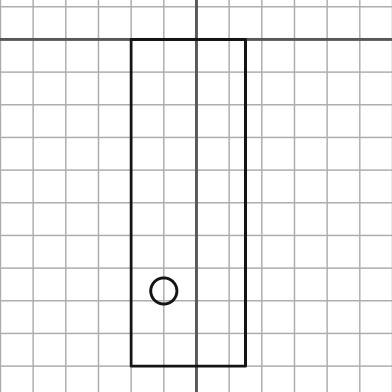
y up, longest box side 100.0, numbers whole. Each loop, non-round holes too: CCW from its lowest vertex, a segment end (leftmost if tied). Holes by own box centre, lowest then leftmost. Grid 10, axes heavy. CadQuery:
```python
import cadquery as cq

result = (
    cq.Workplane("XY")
    .moveTo(-20.0, -100.0)
    .lineTo(15.0, -100.0)
    .lineTo(15.0, 0.0)
    .lineTo(-20.0, 0.0)
    .close()
    .moveTo(-10.0, -77.0)
    .circle(4.0)
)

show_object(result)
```